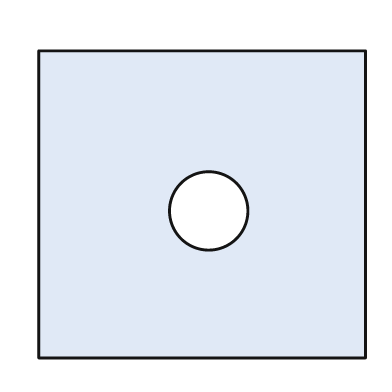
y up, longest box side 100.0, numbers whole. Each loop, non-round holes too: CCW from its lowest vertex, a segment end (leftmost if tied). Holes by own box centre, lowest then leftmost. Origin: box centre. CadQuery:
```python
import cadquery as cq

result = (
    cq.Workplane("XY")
    .moveTo(-50.0, -47.0)
    .lineTo(50.0, -47.0)
    .lineTo(50.0, 47.0)
    .lineTo(-50.0, 47.0)
    .close()
    .moveTo(2.0, -2.0)
    .circle(12.0)
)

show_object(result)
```